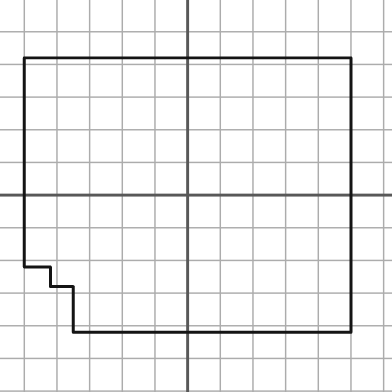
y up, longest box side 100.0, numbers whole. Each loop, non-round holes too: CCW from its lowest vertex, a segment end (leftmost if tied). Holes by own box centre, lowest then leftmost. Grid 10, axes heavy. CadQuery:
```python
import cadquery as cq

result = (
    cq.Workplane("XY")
    .moveTo(-35.0, -42.0)
    .lineTo(50.0, -42.0)
    .lineTo(50.0, 42.0)
    .lineTo(-50.0, 42.0)
    .lineTo(-50.0, -22.0)
    .lineTo(-42.0, -22.0)
    .lineTo(-42.0, -28.0)
    .lineTo(-35.0, -28.0)
    .close()
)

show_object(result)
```